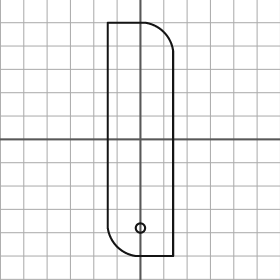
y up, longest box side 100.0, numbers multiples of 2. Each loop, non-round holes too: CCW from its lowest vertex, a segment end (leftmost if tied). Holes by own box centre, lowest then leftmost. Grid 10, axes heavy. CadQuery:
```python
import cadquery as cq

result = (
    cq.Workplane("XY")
    .moveTo(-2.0, -50.0)
    .lineTo(14.0, -50.0)
    .lineTo(14.0, 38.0)
    .threePointArc((10.0, 46.0), (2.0, 50.0))
    .lineTo(-14.0, 50.0)
    .lineTo(-14.0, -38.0)
    .threePointArc((-10.0, -46.0), (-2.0, -50.0))
    .close()
    .moveTo(0.0, -38.0)
    .circle(2.0)
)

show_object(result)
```